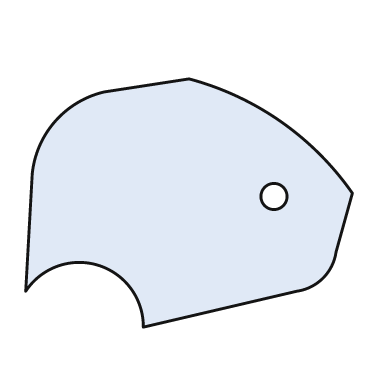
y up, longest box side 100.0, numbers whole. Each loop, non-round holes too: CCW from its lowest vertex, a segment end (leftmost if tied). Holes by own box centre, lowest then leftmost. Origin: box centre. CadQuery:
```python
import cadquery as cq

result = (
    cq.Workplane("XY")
    .moveTo(-14.0, -38.0)
    .lineTo(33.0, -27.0)
    .threePointArc((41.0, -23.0), (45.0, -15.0))
    .lineTo(50.0, 3.0)
    .threePointArc((28.0, 25.0), (0.0, 38.0))
    .lineTo(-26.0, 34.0)
    .threePointArc((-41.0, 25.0), (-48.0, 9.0))
    .lineTo(-50.0, -27.0)
    .threePointArc((-28.0, -19.0), (-14.0, -38.0))
    .close()
    .moveTo(26.0, 2.0)
    .circle(4.0)
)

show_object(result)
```